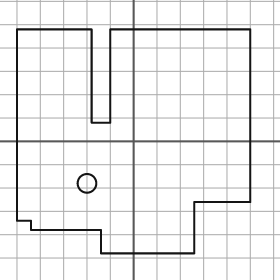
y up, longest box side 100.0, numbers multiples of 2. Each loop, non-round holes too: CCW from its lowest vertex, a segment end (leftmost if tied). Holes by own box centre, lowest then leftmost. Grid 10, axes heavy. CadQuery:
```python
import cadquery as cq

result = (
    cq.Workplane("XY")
    .moveTo(-14.0, -48.0)
    .lineTo(26.0, -48.0)
    .lineTo(26.0, -26.0)
    .lineTo(50.0, -26.0)
    .lineTo(50.0, 48.0)
    .lineTo(-10.0, 48.0)
    .lineTo(-10.0, 8.0)
    .lineTo(-18.0, 8.0)
    .lineTo(-18.0, 48.0)
    .lineTo(-50.0, 48.0)
    .lineTo(-50.0, -34.0)
    .lineTo(-44.0, -34.0)
    .lineTo(-44.0, -38.0)
    .lineTo(-14.0, -38.0)
    .close()
    .moveTo(-20.0, -18.0)
    .circle(4.0)
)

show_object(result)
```